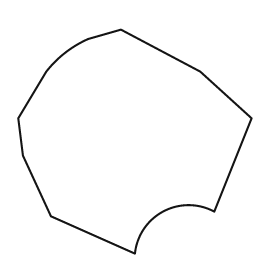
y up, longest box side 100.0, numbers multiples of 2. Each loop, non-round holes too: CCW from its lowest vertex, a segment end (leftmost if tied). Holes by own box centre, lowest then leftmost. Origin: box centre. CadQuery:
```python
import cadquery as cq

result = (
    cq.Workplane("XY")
    .moveTo(0.0, -48.0)
    .threePointArc((12.0, -30.0), (34.0, -30.0))
    .lineTo(50.0, 10.0)
    .lineTo(28.0, 30.0)
    .lineTo(-6.0, 48.0)
    .lineTo(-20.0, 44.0)
    .threePointArc((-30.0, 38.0), (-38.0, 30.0))
    .lineTo(-50.0, 10.0)
    .lineTo(-48.0, -6.0)
    .lineTo(-36.0, -32.0)
    .close()
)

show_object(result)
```